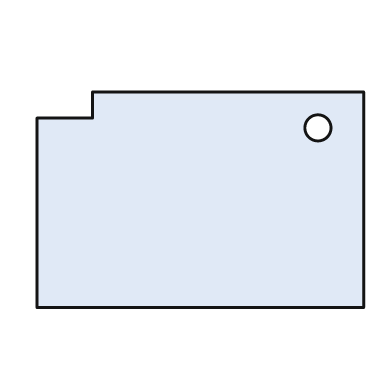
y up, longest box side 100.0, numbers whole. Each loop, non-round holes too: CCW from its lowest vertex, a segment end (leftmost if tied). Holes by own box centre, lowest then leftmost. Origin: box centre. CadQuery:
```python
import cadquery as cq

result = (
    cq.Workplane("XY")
    .moveTo(-50.0, -33.0)
    .lineTo(50.0, -33.0)
    .lineTo(50.0, 33.0)
    .lineTo(-33.0, 33.0)
    .lineTo(-33.0, 25.0)
    .lineTo(-50.0, 25.0)
    .close()
    .moveTo(36.0, 22.0)
    .circle(4.0)
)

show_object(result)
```